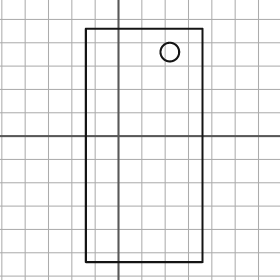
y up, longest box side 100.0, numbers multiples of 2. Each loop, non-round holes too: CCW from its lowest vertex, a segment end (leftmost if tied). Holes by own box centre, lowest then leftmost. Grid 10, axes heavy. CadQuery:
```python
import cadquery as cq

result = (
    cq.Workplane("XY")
    .moveTo(-14.0, -54.0)
    .lineTo(36.0, -54.0)
    .lineTo(36.0, 46.0)
    .lineTo(-14.0, 46.0)
    .close()
    .moveTo(22.0, 36.0)
    .circle(4.0)
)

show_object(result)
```